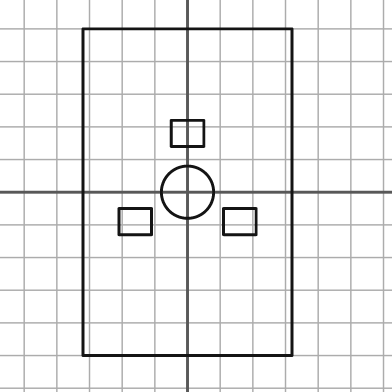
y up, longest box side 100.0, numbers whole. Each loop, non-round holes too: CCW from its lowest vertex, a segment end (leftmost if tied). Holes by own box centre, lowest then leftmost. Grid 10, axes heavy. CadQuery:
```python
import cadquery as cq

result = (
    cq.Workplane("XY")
    .moveTo(-32.0, -50.0)
    .lineTo(32.0, -50.0)
    .lineTo(32.0, 50.0)
    .lineTo(-32.0, 50.0)
    .close()
    .moveTo(-21.0, -13.0)
    .lineTo(-11.0, -13.0)
    .lineTo(-11.0, -5.0)
    .lineTo(-21.0, -5.0)
    .close()
    .moveTo(11.0, -13.0)
    .lineTo(21.0, -13.0)
    .lineTo(21.0, -5.0)
    .lineTo(11.0, -5.0)
    .close()
    .moveTo(0.0, 0.0)
    .circle(8.0)
    .moveTo(-5.0, 14.0)
    .lineTo(5.0, 14.0)
    .lineTo(5.0, 22.0)
    .lineTo(-5.0, 22.0)
    .close()
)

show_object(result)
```